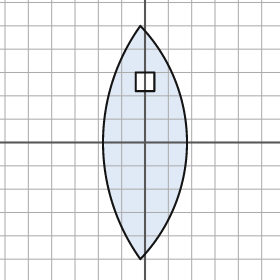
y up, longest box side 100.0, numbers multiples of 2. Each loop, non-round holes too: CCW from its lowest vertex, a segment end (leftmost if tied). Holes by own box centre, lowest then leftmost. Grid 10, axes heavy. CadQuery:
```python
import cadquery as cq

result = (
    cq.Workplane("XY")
    .moveTo(-2.0, -50.0)
    .threePointArc((18.0, 0.0), (-2.0, 50.0))
    .threePointArc((-18.0, 0.0), (-2.0, -50.0))
    .close()
    .moveTo(-4.0, 22.0)
    .lineTo(4.0, 22.0)
    .lineTo(4.0, 30.0)
    .lineTo(-4.0, 30.0)
    .close()
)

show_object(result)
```